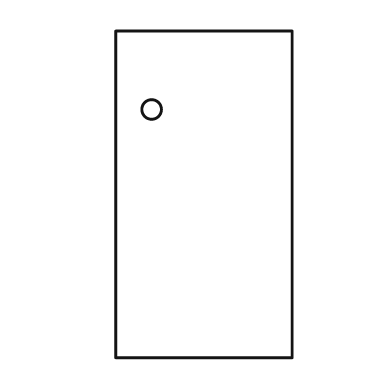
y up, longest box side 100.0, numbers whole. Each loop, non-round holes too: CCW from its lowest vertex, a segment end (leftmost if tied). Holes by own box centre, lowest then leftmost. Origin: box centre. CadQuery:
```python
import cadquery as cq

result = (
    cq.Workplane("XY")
    .moveTo(-27.0, -50.0)
    .lineTo(27.0, -50.0)
    .lineTo(27.0, 50.0)
    .lineTo(-27.0, 50.0)
    .close()
    .moveTo(-16.0, 26.0)
    .circle(3.0)
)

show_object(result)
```